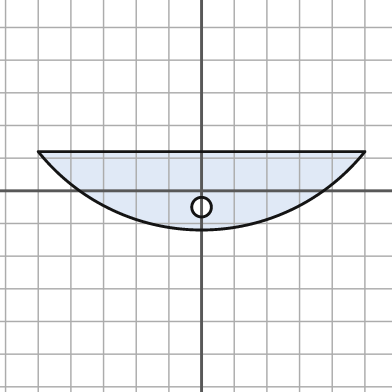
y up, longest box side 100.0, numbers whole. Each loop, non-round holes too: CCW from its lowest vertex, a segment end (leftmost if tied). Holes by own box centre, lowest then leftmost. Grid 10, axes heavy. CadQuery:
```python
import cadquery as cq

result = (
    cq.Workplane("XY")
    .moveTo(-50.0, 12.0)
    .threePointArc((0.0, -12.0), (50.0, 12.0))
    .close()
    .moveTo(0.0, -5.0)
    .circle(3.0)
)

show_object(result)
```